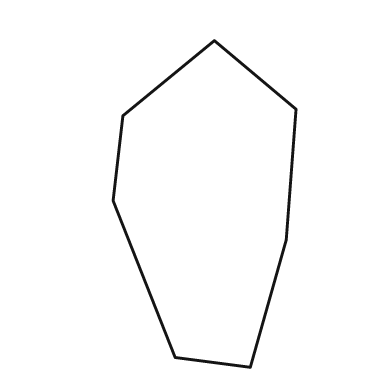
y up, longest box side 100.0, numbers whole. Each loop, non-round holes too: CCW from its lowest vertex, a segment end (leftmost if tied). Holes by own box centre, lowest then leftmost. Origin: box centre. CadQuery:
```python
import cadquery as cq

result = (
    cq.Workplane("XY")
    .moveTo(14.0, -50.0)
    .lineTo(25.0, -11.0)
    .lineTo(28.0, 29.0)
    .lineTo(3.0, 50.0)
    .lineTo(-25.0, 27.0)
    .lineTo(-28.0, 1.0)
    .lineTo(-9.0, -47.0)
    .close()
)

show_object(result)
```